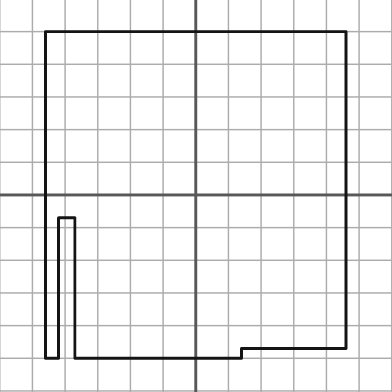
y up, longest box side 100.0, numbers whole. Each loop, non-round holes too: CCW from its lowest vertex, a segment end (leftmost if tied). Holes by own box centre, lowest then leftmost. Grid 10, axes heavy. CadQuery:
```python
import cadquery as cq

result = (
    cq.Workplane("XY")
    .moveTo(-46.0, -50.0)
    .lineTo(-42.0, -50.0)
    .lineTo(-42.0, -7.0)
    .lineTo(-37.0, -7.0)
    .lineTo(-37.0, -50.0)
    .lineTo(14.0, -50.0)
    .lineTo(14.0, -47.0)
    .lineTo(46.0, -47.0)
    .lineTo(46.0, 50.0)
    .lineTo(-46.0, 50.0)
    .close()
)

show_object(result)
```